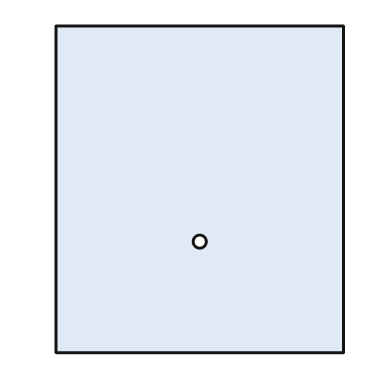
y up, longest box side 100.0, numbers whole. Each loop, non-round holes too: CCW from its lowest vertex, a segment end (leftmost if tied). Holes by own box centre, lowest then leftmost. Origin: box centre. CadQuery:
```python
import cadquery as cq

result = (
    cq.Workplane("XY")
    .moveTo(-44.0, -50.0)
    .lineTo(44.0, -50.0)
    .lineTo(44.0, 50.0)
    .lineTo(-44.0, 50.0)
    .close()
    .moveTo(0.0, -16.0)
    .circle(2.0)
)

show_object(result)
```